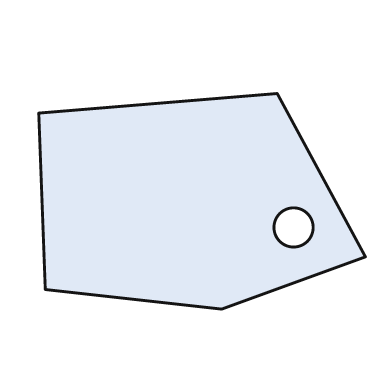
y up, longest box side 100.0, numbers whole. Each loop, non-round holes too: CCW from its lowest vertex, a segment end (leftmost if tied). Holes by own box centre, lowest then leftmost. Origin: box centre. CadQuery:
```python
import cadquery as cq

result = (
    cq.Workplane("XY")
    .moveTo(6.0, -33.0)
    .lineTo(50.0, -17.0)
    .lineTo(23.0, 33.0)
    .lineTo(-50.0, 27.0)
    .lineTo(-48.0, -27.0)
    .close()
    .moveTo(28.0, -8.0)
    .circle(6.0)
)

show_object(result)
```